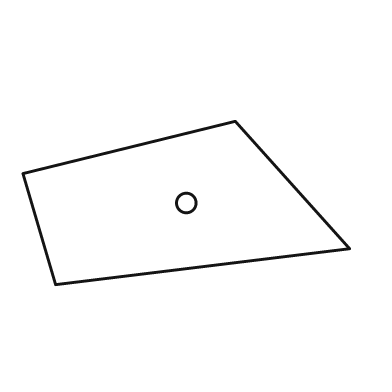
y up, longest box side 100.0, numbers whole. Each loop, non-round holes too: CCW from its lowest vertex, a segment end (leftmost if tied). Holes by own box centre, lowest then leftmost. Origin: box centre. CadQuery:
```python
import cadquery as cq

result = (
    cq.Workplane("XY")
    .moveTo(-40.0, -25.0)
    .lineTo(50.0, -14.0)
    .lineTo(15.0, 25.0)
    .lineTo(-50.0, 9.0)
    .close()
    .moveTo(0.0, 0.0)
    .circle(3.0)
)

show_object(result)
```